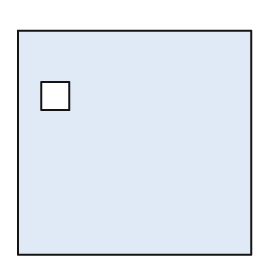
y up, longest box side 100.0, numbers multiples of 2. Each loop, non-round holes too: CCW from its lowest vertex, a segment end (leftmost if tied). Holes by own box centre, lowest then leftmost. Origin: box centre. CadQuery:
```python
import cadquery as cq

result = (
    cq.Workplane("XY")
    .moveTo(-50.0, -48.0)
    .lineTo(50.0, -48.0)
    .lineTo(50.0, 48.0)
    .lineTo(-50.0, 48.0)
    .close()
    .moveTo(-40.0, 14.0)
    .lineTo(-28.0, 14.0)
    .lineTo(-28.0, 26.0)
    .lineTo(-40.0, 26.0)
    .close()
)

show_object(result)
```